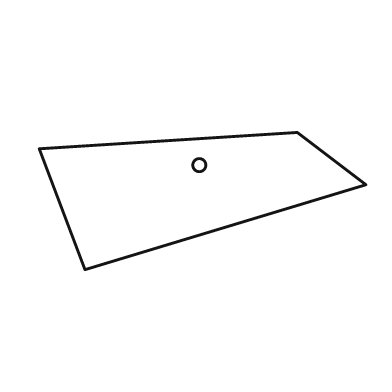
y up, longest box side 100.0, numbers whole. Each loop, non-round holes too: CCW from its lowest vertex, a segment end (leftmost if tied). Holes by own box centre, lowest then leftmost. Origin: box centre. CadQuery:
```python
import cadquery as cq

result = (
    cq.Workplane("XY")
    .moveTo(-36.0, -21.0)
    .lineTo(50.0, 5.0)
    .lineTo(29.0, 21.0)
    .lineTo(-50.0, 16.0)
    .close()
    .moveTo(-1.0, 11.0)
    .circle(2.0)
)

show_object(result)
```